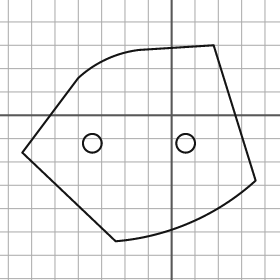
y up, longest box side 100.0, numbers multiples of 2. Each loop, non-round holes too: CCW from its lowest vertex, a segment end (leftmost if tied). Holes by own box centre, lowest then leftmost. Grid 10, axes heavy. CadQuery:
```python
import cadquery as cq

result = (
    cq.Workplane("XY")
    .moveTo(-24.0, -54.0)
    .threePointArc((8.0, -46.0), (36.0, -28.0))
    .lineTo(18.0, 30.0)
    .lineTo(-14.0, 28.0)
    .threePointArc((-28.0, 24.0), (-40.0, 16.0))
    .lineTo(-64.0, -16.0)
    .close()
    .moveTo(-34.0, -12.0)
    .circle(4.0)
    .moveTo(6.0, -12.0)
    .circle(4.0)
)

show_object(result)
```